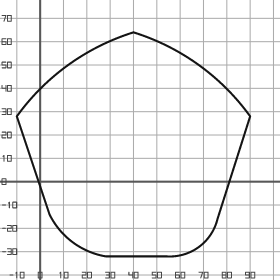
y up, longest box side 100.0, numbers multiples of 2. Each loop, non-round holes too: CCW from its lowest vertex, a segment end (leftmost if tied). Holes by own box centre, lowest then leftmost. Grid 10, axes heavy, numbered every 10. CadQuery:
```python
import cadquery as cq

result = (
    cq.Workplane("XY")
    .moveTo(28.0, -32.0)
    .lineTo(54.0, -32.0)
    .threePointArc((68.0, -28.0), (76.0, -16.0))
    .lineTo(90.0, 28.0)
    .threePointArc((68.0, 50.0), (40.0, 64.0))
    .threePointArc((12.0, 50.0), (-10.0, 28.0))
    .lineTo(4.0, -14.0)
    .threePointArc((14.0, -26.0), (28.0, -32.0))
    .close()
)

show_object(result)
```